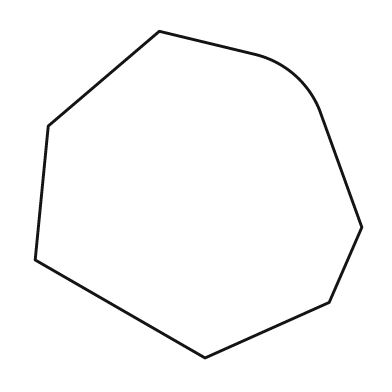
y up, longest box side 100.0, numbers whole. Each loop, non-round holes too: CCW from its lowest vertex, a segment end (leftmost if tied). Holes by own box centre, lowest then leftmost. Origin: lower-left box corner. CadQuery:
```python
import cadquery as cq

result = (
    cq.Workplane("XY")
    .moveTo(52.0, 0.0)
    .lineTo(90.0, 17.0)
    .lineTo(100.0, 40.0)
    .lineTo(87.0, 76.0)
    .threePointArc((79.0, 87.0), (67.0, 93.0))
    .lineTo(38.0, 100.0)
    .lineTo(4.0, 71.0)
    .lineTo(0.0, 30.0)
    .close()
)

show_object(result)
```